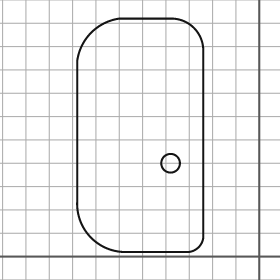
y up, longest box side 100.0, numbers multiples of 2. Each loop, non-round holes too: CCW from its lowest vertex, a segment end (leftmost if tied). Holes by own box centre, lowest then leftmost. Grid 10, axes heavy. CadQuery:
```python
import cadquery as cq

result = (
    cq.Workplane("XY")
    .moveTo(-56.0, 2.0)
    .lineTo(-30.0, 2.0)
    .threePointArc((-26.0, 4.0), (-24.0, 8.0))
    .lineTo(-24.0, 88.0)
    .threePointArc((-28.0, 98.0), (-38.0, 102.0))
    .lineTo(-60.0, 102.0)
    .threePointArc((-72.0, 96.0), (-78.0, 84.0))
    .lineTo(-78.0, 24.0)
    .threePointArc((-72.0, 8.0), (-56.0, 2.0))
    .close()
    .moveTo(-38.0, 40.0)
    .circle(4.0)
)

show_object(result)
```